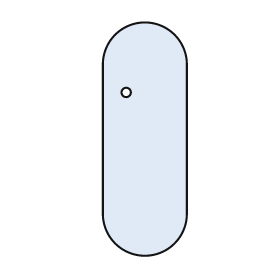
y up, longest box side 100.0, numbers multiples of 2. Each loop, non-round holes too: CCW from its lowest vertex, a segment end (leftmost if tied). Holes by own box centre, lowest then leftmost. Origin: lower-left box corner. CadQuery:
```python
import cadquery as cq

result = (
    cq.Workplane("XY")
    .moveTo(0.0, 18.0)
    .threePointArc((18.0, 0.0), (36.0, 18.0))
    .lineTo(36.0, 82.0)
    .threePointArc((18.0, 100.0), (0.0, 82.0))
    .close()
    .moveTo(10.0, 70.0)
    .circle(2.0)
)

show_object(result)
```